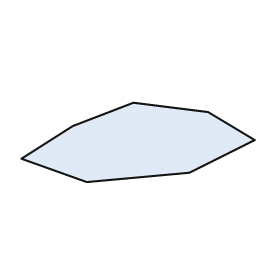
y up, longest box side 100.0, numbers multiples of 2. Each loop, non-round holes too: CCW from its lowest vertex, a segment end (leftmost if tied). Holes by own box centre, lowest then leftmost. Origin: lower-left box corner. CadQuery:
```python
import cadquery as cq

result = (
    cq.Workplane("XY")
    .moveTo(28.0, 0.0)
    .lineTo(72.0, 4.0)
    .lineTo(100.0, 18.0)
    .lineTo(80.0, 30.0)
    .lineTo(48.0, 34.0)
    .lineTo(22.0, 24.0)
    .lineTo(0.0, 10.0)
    .close()
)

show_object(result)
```